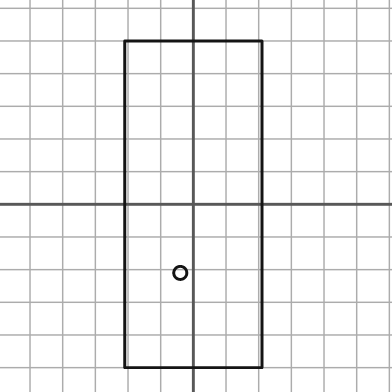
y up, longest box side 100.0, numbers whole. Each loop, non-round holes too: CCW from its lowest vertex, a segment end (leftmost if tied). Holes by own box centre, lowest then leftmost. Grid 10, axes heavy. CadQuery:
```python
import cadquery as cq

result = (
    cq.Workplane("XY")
    .moveTo(-21.0, -50.0)
    .lineTo(21.0, -50.0)
    .lineTo(21.0, 50.0)
    .lineTo(-21.0, 50.0)
    .close()
    .moveTo(-4.0, -21.0)
    .circle(2.0)
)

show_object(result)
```